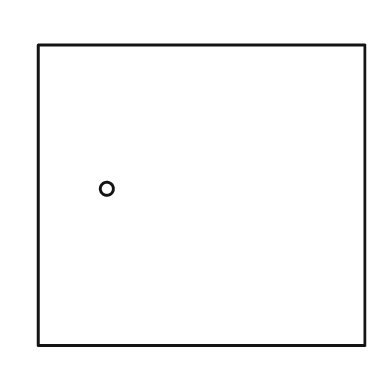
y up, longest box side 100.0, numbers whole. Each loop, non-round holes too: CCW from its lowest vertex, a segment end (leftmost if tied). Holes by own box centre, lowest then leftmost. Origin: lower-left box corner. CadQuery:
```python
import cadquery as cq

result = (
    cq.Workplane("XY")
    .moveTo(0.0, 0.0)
    .lineTo(100.0, 0.0)
    .lineTo(100.0, 92.0)
    .lineTo(0.0, 92.0)
    .close()
    .moveTo(21.0, 48.0)
    .circle(2.0)
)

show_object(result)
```